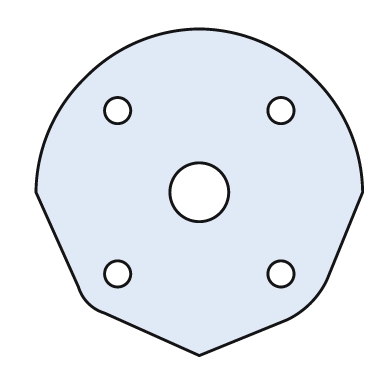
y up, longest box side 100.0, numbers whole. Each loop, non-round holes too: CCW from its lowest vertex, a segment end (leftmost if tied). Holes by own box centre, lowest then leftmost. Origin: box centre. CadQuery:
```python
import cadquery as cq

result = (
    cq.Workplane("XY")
    .moveTo(0.0, -50.0)
    .lineTo(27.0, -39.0)
    .threePointArc((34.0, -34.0), (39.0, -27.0))
    .lineTo(50.0, 0.0)
    .threePointArc((46.0, 19.0), (35.0, 35.0))
    .threePointArc((19.0, 46.0), (0.0, 50.0))
    .threePointArc((-19.0, 46.0), (-35.0, 35.0))
    .threePointArc((-46.0, 19.0), (-50.0, 0.0))
    .lineTo(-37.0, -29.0)
    .threePointArc((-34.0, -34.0), (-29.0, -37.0))
    .close()
    .moveTo(-25.0, -25.0)
    .circle(4.0)
    .moveTo(25.0, -25.0)
    .circle(4.0)
    .moveTo(0.0, 0.0)
    .circle(9.0)
    .moveTo(-25.0, 25.0)
    .circle(4.0)
    .moveTo(25.0, 25.0)
    .circle(4.0)
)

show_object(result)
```